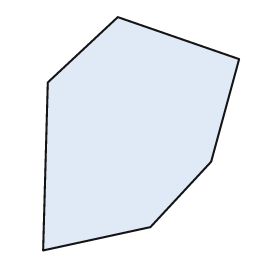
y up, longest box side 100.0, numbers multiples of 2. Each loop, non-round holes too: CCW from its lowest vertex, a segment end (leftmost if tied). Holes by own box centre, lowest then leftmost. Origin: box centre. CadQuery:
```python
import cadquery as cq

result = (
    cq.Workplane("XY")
    .moveTo(-42.0, -50.0)
    .lineTo(4.0, -40.0)
    .lineTo(30.0, -12.0)
    .lineTo(42.0, 32.0)
    .lineTo(-10.0, 50.0)
    .lineTo(-40.0, 22.0)
    .close()
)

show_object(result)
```